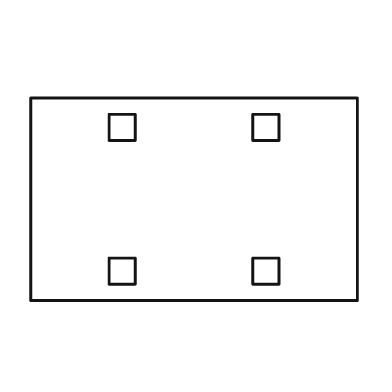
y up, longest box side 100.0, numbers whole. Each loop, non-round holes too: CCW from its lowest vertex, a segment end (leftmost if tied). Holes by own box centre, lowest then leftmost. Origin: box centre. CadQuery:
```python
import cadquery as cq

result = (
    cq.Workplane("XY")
    .moveTo(-50.0, -31.0)
    .lineTo(50.0, -31.0)
    .lineTo(50.0, 31.0)
    .lineTo(-50.0, 31.0)
    .close()
    .moveTo(-26.0, -26.0)
    .lineTo(-18.0, -26.0)
    .lineTo(-18.0, -18.0)
    .lineTo(-26.0, -18.0)
    .close()
    .moveTo(18.0, -26.0)
    .lineTo(26.0, -26.0)
    .lineTo(26.0, -18.0)
    .lineTo(18.0, -18.0)
    .close()
    .moveTo(-26.0, 18.0)
    .lineTo(-18.0, 18.0)
    .lineTo(-18.0, 26.0)
    .lineTo(-26.0, 26.0)
    .close()
    .moveTo(18.0, 18.0)
    .lineTo(26.0, 18.0)
    .lineTo(26.0, 26.0)
    .lineTo(18.0, 26.0)
    .close()
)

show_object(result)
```